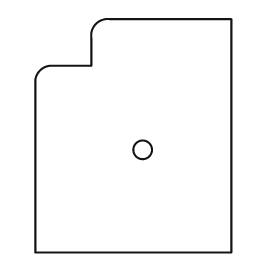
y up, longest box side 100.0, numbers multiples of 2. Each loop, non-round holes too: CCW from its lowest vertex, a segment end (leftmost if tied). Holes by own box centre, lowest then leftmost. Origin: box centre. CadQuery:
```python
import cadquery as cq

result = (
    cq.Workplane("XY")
    .moveTo(-42.0, -50.0)
    .lineTo(42.0, -50.0)
    .lineTo(42.0, 50.0)
    .lineTo(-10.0, 50.0)
    .threePointArc((-16.0, 48.0), (-18.0, 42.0))
    .lineTo(-18.0, 30.0)
    .lineTo(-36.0, 30.0)
    .threePointArc((-40.0, 28.0), (-42.0, 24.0))
    .close()
    .moveTo(4.0, -6.0)
    .circle(4.0)
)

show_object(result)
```